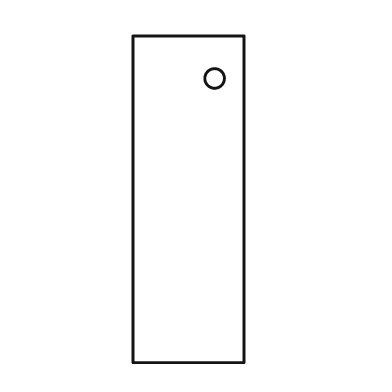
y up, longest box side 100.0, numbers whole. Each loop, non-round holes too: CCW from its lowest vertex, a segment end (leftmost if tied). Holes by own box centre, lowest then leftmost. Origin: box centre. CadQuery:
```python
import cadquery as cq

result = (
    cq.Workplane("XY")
    .moveTo(-17.0, -50.0)
    .lineTo(17.0, -50.0)
    .lineTo(17.0, 50.0)
    .lineTo(-17.0, 50.0)
    .close()
    .moveTo(8.0, 37.0)
    .circle(3.0)
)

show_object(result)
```